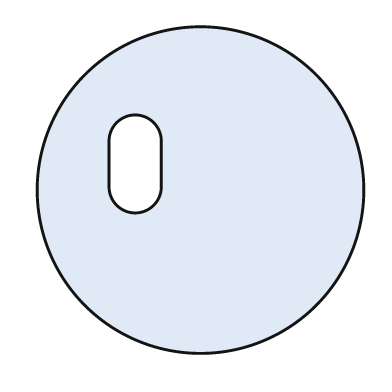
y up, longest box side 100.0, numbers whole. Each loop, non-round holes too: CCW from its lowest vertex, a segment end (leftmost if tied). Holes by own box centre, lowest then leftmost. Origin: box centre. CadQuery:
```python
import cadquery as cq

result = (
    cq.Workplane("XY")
    .moveTo(0.0, 0.0)
    .circle(50.0)
    .moveTo(-28.0, 1.0)
    .threePointArc((-20.0, -7.0), (-12.0, 1.0))
    .lineTo(-12.0, 15.0)
    .threePointArc((-20.0, 23.0), (-28.0, 15.0))
    .close()
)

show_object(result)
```